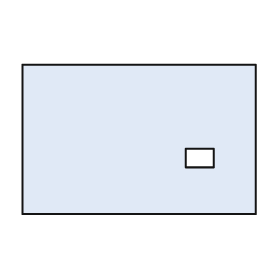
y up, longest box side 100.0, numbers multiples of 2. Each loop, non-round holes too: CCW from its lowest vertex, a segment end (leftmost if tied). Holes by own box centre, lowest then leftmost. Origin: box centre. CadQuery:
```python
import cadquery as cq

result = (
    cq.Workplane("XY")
    .moveTo(-50.0, -32.0)
    .lineTo(50.0, -32.0)
    .lineTo(50.0, 32.0)
    .lineTo(-50.0, 32.0)
    .close()
    .moveTo(20.0, -12.0)
    .lineTo(32.0, -12.0)
    .lineTo(32.0, -4.0)
    .lineTo(20.0, -4.0)
    .close()
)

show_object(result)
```